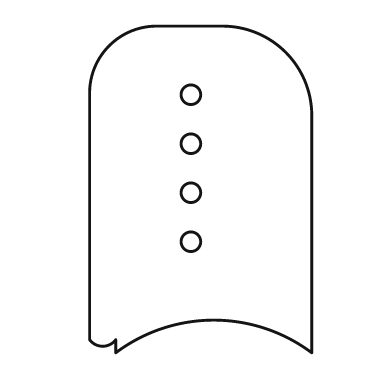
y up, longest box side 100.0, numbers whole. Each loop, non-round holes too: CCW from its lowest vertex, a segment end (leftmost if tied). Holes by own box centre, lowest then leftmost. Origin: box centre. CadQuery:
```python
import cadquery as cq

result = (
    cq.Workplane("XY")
    .moveTo(-26.0, -50.0)
    .threePointArc((4.0, -40.0), (34.0, -50.0))
    .lineTo(34.0, 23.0)
    .threePointArc((26.0, 42.0), (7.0, 50.0))
    .lineTo(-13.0, 50.0)
    .threePointArc((-28.0, 44.0), (-34.0, 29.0))
    .lineTo(-34.0, -46.0)
    .threePointArc((-30.0, -48.0), (-26.0, -46.0))
    .close()
    .moveTo(-3.0, -16.0)
    .circle(3.0)
    .moveTo(-3.0, -1.0)
    .circle(3.0)
    .moveTo(-3.0, 14.0)
    .circle(3.0)
    .moveTo(-3.0, 29.0)
    .circle(3.0)
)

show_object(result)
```